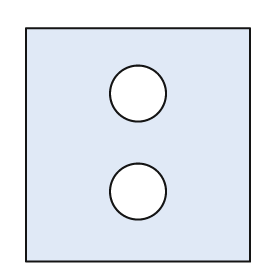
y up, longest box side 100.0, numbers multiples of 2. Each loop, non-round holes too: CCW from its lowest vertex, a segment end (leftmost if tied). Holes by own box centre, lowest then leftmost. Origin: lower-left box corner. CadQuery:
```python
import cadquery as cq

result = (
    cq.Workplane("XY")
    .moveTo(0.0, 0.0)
    .lineTo(96.0, 0.0)
    .lineTo(96.0, 100.0)
    .lineTo(0.0, 100.0)
    .close()
    .moveTo(48.0, 30.0)
    .circle(12.0)
    .moveTo(48.0, 72.0)
    .circle(12.0)
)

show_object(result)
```